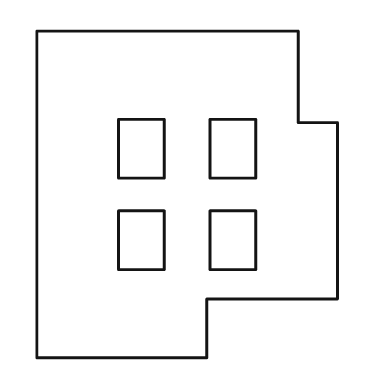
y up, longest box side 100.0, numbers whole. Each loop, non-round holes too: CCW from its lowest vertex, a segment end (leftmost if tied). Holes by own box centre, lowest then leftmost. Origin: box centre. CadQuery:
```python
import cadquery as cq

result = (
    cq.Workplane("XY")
    .moveTo(-46.0, -50.0)
    .lineTo(6.0, -50.0)
    .lineTo(6.0, -32.0)
    .lineTo(46.0, -32.0)
    .lineTo(46.0, 22.0)
    .lineTo(34.0, 22.0)
    .lineTo(34.0, 50.0)
    .lineTo(-46.0, 50.0)
    .close()
    .moveTo(-21.0, -23.0)
    .lineTo(-7.0, -23.0)
    .lineTo(-7.0, -5.0)
    .lineTo(-21.0, -5.0)
    .close()
    .moveTo(7.0, -23.0)
    .lineTo(21.0, -23.0)
    .lineTo(21.0, -5.0)
    .lineTo(7.0, -5.0)
    .close()
    .moveTo(-21.0, 5.0)
    .lineTo(-7.0, 5.0)
    .lineTo(-7.0, 23.0)
    .lineTo(-21.0, 23.0)
    .close()
    .moveTo(7.0, 5.0)
    .lineTo(21.0, 5.0)
    .lineTo(21.0, 23.0)
    .lineTo(7.0, 23.0)
    .close()
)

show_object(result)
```